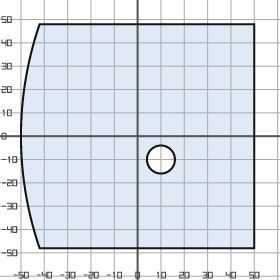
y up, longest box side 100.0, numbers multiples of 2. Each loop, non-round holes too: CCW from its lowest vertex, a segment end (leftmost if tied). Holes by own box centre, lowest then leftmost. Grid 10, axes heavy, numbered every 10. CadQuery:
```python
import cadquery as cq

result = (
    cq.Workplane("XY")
    .moveTo(-42.0, -48.0)
    .lineTo(50.0, -48.0)
    .lineTo(50.0, 48.0)
    .lineTo(-42.0, 48.0)
    .threePointArc((-50.0, 0.0), (-42.0, -48.0))
    .close()
    .moveTo(10.0, -10.0)
    .circle(6.0)
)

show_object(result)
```